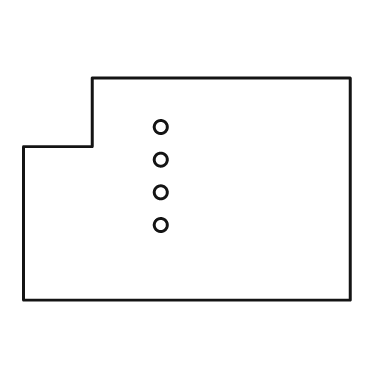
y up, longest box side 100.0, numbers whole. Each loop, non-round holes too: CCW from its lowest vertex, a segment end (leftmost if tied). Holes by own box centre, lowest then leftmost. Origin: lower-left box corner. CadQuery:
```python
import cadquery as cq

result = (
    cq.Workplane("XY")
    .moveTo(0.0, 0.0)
    .lineTo(100.0, 0.0)
    .lineTo(100.0, 68.0)
    .lineTo(21.0, 68.0)
    .lineTo(21.0, 47.0)
    .lineTo(0.0, 47.0)
    .close()
    .moveTo(42.0, 23.0)
    .circle(2.0)
    .moveTo(42.0, 33.0)
    .circle(2.0)
    .moveTo(42.0, 43.0)
    .circle(2.0)
    .moveTo(42.0, 53.0)
    .circle(2.0)
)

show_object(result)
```